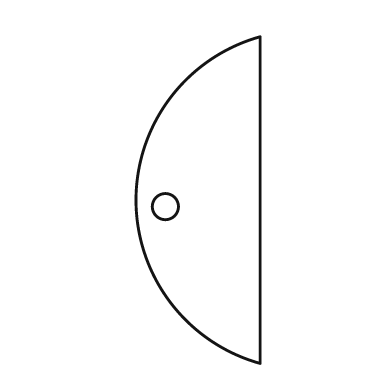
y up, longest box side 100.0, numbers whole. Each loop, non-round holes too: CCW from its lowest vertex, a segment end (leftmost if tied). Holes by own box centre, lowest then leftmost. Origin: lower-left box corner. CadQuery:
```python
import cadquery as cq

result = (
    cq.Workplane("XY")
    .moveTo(38.0, 0.0)
    .lineTo(38.0, 100.0)
    .threePointArc((0.0, 50.0), (38.0, 0.0))
    .close()
    .moveTo(9.0, 48.0)
    .circle(4.0)
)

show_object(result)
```